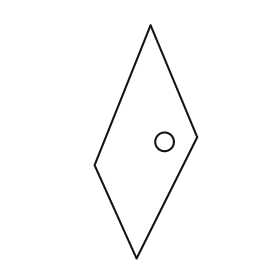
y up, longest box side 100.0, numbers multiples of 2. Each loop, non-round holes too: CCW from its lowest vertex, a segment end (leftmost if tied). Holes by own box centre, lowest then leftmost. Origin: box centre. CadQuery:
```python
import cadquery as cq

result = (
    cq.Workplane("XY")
    .moveTo(-4.0, -50.0)
    .lineTo(22.0, 2.0)
    .lineTo(2.0, 50.0)
    .lineTo(-22.0, -10.0)
    .close()
    .moveTo(8.0, 0.0)
    .circle(4.0)
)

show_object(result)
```